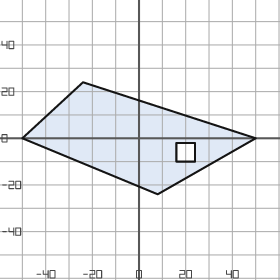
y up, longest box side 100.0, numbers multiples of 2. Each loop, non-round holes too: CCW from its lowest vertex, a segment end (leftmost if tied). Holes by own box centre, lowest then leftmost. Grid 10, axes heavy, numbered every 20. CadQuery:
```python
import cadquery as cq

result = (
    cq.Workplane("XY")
    .moveTo(8.0, -24.0)
    .lineTo(50.0, 0.0)
    .lineTo(-24.0, 24.0)
    .lineTo(-50.0, 0.0)
    .close()
    .moveTo(16.0, -10.0)
    .lineTo(24.0, -10.0)
    .lineTo(24.0, -2.0)
    .lineTo(16.0, -2.0)
    .close()
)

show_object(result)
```